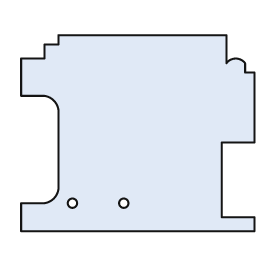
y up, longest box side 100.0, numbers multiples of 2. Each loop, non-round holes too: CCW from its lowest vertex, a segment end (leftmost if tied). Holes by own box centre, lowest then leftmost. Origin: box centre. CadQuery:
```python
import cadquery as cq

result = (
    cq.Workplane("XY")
    .moveTo(-50.0, -42.0)
    .lineTo(50.0, -42.0)
    .lineTo(50.0, -36.0)
    .lineTo(36.0, -36.0)
    .lineTo(36.0, -4.0)
    .lineTo(50.0, -4.0)
    .lineTo(50.0, 26.0)
    .lineTo(46.0, 26.0)
    .lineTo(46.0, 30.0)
    .threePointArc((42.0, 32.0), (38.0, 30.0))
    .lineTo(38.0, 42.0)
    .lineTo(-34.0, 42.0)
    .lineTo(-34.0, 38.0)
    .lineTo(-40.0, 38.0)
    .lineTo(-40.0, 32.0)
    .lineTo(-50.0, 32.0)
    .lineTo(-50.0, 16.0)
    .lineTo(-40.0, 16.0)
    .threePointArc((-36.0, 14.0), (-34.0, 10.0))
    .lineTo(-34.0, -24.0)
    .threePointArc((-36.0, -28.0), (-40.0, -30.0))
    .lineTo(-50.0, -30.0)
    .close()
    .moveTo(-28.0, -30.0)
    .circle(2.0)
    .moveTo(-6.0, -30.0)
    .circle(2.0)
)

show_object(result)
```